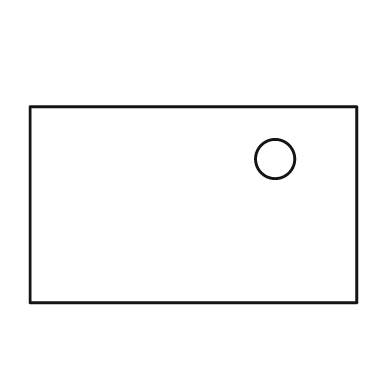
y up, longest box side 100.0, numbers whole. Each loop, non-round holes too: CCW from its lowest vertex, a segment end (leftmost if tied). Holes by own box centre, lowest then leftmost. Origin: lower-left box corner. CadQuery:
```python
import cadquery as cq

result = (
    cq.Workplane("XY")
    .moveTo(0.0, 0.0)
    .lineTo(100.0, 0.0)
    .lineTo(100.0, 60.0)
    .lineTo(0.0, 60.0)
    .close()
    .moveTo(75.0, 44.0)
    .circle(6.0)
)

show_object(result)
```